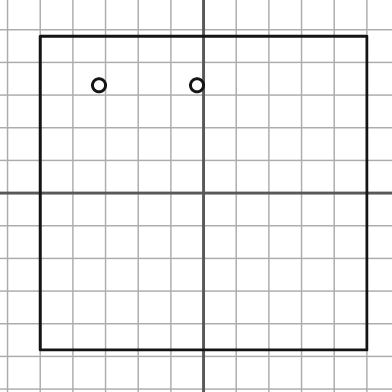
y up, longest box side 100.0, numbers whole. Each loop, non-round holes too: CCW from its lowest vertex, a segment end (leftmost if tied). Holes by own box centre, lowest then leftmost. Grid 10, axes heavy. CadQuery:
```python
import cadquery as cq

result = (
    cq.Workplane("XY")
    .moveTo(-50.0, -48.0)
    .lineTo(50.0, -48.0)
    .lineTo(50.0, 48.0)
    .lineTo(-50.0, 48.0)
    .close()
    .moveTo(-32.0, 33.0)
    .circle(2.0)
    .moveTo(-2.0, 33.0)
    .circle(2.0)
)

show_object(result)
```